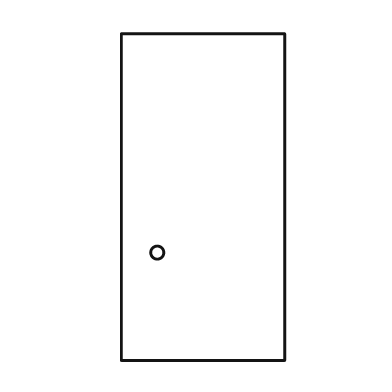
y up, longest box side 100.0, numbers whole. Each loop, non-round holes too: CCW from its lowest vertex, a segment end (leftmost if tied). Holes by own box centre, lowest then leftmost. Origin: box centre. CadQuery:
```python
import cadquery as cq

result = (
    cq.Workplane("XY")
    .moveTo(-25.0, -50.0)
    .lineTo(25.0, -50.0)
    .lineTo(25.0, 50.0)
    .lineTo(-25.0, 50.0)
    .close()
    .moveTo(-14.0, -17.0)
    .circle(2.0)
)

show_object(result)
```